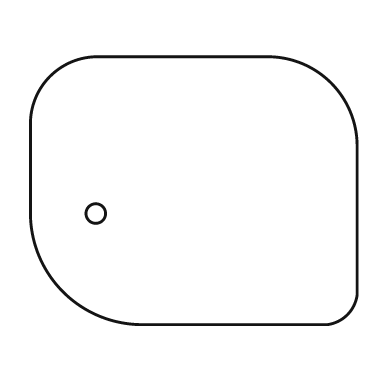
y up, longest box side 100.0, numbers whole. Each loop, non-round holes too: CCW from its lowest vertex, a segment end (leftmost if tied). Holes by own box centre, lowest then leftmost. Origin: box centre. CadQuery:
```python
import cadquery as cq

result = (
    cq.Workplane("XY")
    .moveTo(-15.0, -41.0)
    .lineTo(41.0, -41.0)
    .threePointArc((47.0, -38.0), (50.0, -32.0))
    .lineTo(50.0, 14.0)
    .threePointArc((42.0, 33.0), (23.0, 41.0))
    .lineTo(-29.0, 41.0)
    .threePointArc((-44.0, 35.0), (-50.0, 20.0))
    .lineTo(-50.0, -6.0)
    .threePointArc((-40.0, -31.0), (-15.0, -41.0))
    .close()
    .moveTo(-30.0, -7.0)
    .circle(3.0)
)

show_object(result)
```